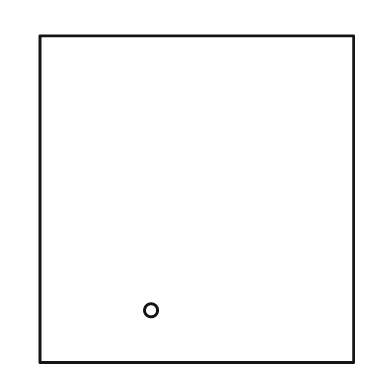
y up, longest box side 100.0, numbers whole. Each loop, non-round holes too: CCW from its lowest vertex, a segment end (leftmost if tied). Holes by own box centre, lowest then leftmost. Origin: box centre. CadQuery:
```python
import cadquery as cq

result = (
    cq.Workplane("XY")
    .moveTo(-48.0, -50.0)
    .lineTo(48.0, -50.0)
    .lineTo(48.0, 50.0)
    .lineTo(-48.0, 50.0)
    .close()
    .moveTo(-14.0, -34.0)
    .circle(2.0)
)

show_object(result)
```